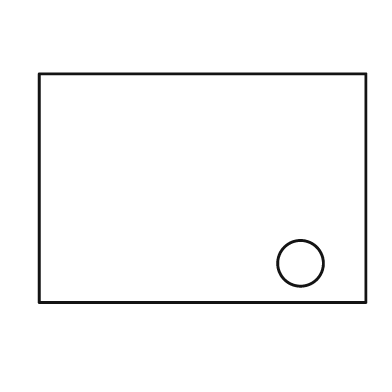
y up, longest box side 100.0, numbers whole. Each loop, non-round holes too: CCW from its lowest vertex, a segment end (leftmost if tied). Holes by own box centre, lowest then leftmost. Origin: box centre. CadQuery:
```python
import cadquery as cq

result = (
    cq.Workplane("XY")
    .moveTo(-50.0, -35.0)
    .lineTo(50.0, -35.0)
    .lineTo(50.0, 35.0)
    .lineTo(-50.0, 35.0)
    .close()
    .moveTo(30.0, -23.0)
    .circle(7.0)
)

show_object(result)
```